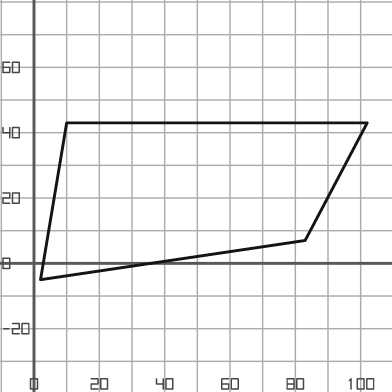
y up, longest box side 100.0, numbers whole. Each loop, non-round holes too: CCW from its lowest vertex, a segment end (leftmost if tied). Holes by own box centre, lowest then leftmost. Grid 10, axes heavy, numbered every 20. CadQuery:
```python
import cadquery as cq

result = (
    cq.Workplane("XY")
    .moveTo(2.0, -5.0)
    .lineTo(83.0, 7.0)
    .lineTo(102.0, 43.0)
    .lineTo(10.0, 43.0)
    .close()
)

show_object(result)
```